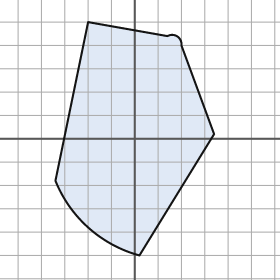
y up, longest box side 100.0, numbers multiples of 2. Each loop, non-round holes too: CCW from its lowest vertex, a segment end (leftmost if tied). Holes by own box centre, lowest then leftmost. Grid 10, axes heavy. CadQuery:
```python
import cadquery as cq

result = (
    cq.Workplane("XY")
    .moveTo(2.0, -50.0)
    .lineTo(34.0, 2.0)
    .lineTo(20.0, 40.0)
    .threePointArc((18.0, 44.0), (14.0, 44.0))
    .lineTo(-20.0, 50.0)
    .lineTo(-34.0, -18.0)
    .threePointArc((-20.0, -38.0), (2.0, -50.0))
    .close()
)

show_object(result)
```